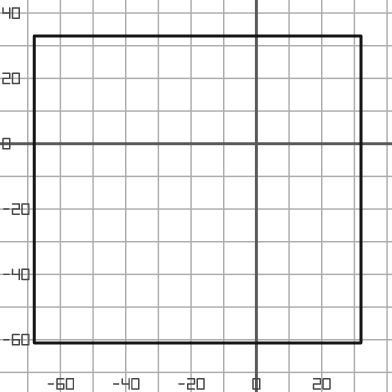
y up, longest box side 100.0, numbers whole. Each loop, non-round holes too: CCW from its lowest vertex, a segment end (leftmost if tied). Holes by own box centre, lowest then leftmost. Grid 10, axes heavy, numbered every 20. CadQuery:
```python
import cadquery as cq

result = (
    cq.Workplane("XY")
    .moveTo(-68.0, -61.0)
    .lineTo(32.0, -61.0)
    .lineTo(32.0, 33.0)
    .lineTo(-68.0, 33.0)
    .close()
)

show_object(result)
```